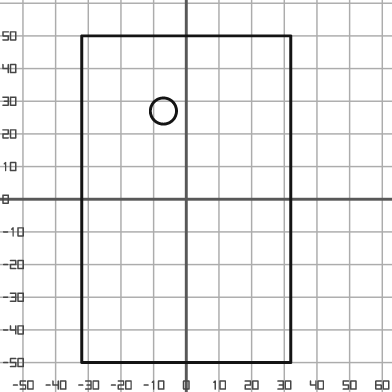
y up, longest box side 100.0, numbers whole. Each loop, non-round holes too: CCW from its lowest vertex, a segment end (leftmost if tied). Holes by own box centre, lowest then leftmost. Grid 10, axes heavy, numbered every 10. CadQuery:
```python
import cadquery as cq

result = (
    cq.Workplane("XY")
    .moveTo(-32.0, -50.0)
    .lineTo(32.0, -50.0)
    .lineTo(32.0, 50.0)
    .lineTo(-32.0, 50.0)
    .close()
    .moveTo(-7.0, 27.0)
    .circle(4.0)
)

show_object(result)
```